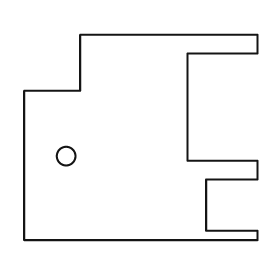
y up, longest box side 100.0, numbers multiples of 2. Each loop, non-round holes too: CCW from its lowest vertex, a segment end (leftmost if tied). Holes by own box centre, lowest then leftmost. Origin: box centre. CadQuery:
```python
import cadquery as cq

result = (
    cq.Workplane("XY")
    .moveTo(-50.0, -44.0)
    .lineTo(50.0, -44.0)
    .lineTo(50.0, -40.0)
    .lineTo(28.0, -40.0)
    .lineTo(28.0, -18.0)
    .lineTo(50.0, -18.0)
    .lineTo(50.0, -10.0)
    .lineTo(20.0, -10.0)
    .lineTo(20.0, 36.0)
    .lineTo(50.0, 36.0)
    .lineTo(50.0, 44.0)
    .lineTo(-26.0, 44.0)
    .lineTo(-26.0, 20.0)
    .lineTo(-50.0, 20.0)
    .close()
    .moveTo(-32.0, -8.0)
    .circle(4.0)
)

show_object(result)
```